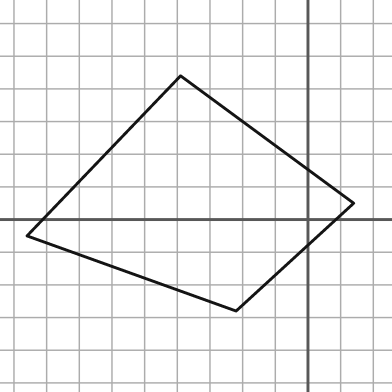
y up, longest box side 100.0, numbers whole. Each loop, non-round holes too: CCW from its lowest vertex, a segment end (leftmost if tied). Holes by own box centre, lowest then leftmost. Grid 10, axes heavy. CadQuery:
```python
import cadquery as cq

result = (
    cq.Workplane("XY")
    .moveTo(-22.0, -28.0)
    .lineTo(14.0, 5.0)
    .lineTo(-39.0, 44.0)
    .lineTo(-86.0, -5.0)
    .close()
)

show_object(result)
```